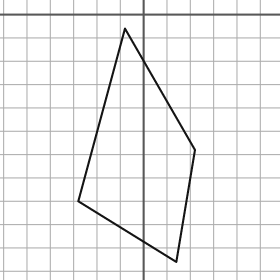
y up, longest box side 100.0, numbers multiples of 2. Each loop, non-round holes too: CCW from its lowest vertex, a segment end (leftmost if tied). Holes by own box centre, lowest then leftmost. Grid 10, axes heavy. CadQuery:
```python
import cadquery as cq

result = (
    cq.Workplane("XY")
    .moveTo(14.0, -106.0)
    .lineTo(22.0, -58.0)
    .lineTo(-8.0, -6.0)
    .lineTo(-28.0, -80.0)
    .close()
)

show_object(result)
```